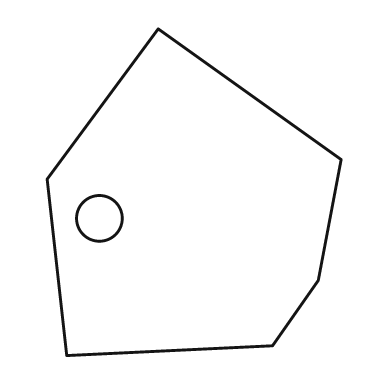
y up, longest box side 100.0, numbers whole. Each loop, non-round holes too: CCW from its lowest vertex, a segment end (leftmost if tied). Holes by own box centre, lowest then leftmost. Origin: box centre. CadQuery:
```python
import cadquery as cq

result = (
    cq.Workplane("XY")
    .moveTo(-39.0, -50.0)
    .lineTo(24.0, -47.0)
    .lineTo(38.0, -27.0)
    .lineTo(45.0, 10.0)
    .lineTo(-11.0, 50.0)
    .lineTo(-45.0, 4.0)
    .close()
    .moveTo(-29.0, -8.0)
    .circle(7.0)
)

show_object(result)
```